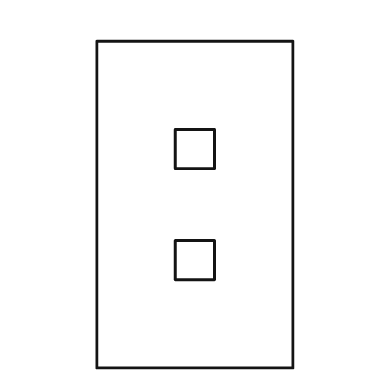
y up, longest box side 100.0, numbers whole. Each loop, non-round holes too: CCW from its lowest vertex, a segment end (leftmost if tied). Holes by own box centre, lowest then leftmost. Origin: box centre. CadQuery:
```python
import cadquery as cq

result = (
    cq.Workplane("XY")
    .moveTo(-30.0, -50.0)
    .lineTo(30.0, -50.0)
    .lineTo(30.0, 50.0)
    .lineTo(-30.0, 50.0)
    .close()
    .moveTo(-6.0, -23.0)
    .lineTo(6.0, -23.0)
    .lineTo(6.0, -11.0)
    .lineTo(-6.0, -11.0)
    .close()
    .moveTo(-6.0, 11.0)
    .lineTo(6.0, 11.0)
    .lineTo(6.0, 23.0)
    .lineTo(-6.0, 23.0)
    .close()
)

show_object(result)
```